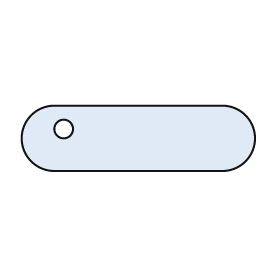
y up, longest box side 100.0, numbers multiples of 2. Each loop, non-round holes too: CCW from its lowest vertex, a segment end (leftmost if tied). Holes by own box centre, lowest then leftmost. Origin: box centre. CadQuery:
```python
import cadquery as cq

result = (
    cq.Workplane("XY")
    .moveTo(-36.0, -14.0)
    .lineTo(36.0, -14.0)
    .threePointArc((50.0, 0.0), (36.0, 14.0))
    .lineTo(-36.0, 14.0)
    .threePointArc((-50.0, 0.0), (-36.0, -14.0))
    .close()
    .moveTo(-32.0, 4.0)
    .circle(4.0)
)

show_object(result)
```